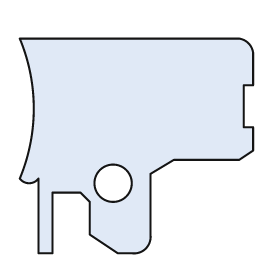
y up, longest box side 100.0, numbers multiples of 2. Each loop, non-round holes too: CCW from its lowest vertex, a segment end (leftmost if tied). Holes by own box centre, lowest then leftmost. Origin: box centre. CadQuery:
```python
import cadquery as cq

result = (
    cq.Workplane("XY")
    .moveTo(-42.0, -46.0)
    .lineTo(-36.0, -46.0)
    .lineTo(-36.0, -20.0)
    .lineTo(-24.0, -20.0)
    .lineTo(-20.0, -24.0)
    .lineTo(-20.0, -38.0)
    .lineTo(-8.0, -46.0)
    .lineTo(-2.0, -46.0)
    .threePointArc((4.0, -44.0), (6.0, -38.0))
    .lineTo(6.0, -12.0)
    .lineTo(16.0, -6.0)
    .lineTo(44.0, -6.0)
    .lineTo(50.0, -2.0)
    .lineTo(50.0, 8.0)
    .lineTo(46.0, 8.0)
    .lineTo(46.0, 26.0)
    .lineTo(50.0, 26.0)
    .lineTo(50.0, 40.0)
    .threePointArc((48.0, 44.0), (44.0, 46.0))
    .lineTo(-50.0, 46.0)
    .threePointArc((-44.0, 16.0), (-50.0, -14.0))
    .threePointArc((-46.0, -16.0), (-42.0, -14.0))
    .close()
    .moveTo(-10.0, -16.0)
    .circle(8.0)
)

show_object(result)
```